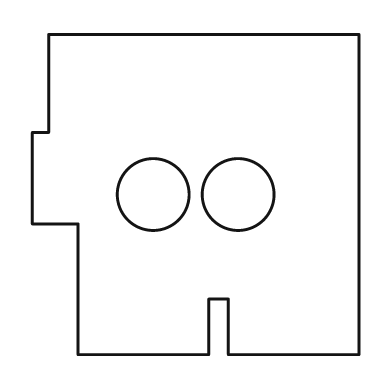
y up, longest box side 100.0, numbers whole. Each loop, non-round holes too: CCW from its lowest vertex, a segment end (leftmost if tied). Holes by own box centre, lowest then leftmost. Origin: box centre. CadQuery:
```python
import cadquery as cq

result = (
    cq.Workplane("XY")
    .moveTo(-36.0, -49.0)
    .lineTo(4.0, -49.0)
    .lineTo(4.0, -32.0)
    .lineTo(10.0, -32.0)
    .lineTo(10.0, -49.0)
    .lineTo(50.0, -49.0)
    .lineTo(50.0, 49.0)
    .lineTo(-45.0, 49.0)
    .lineTo(-45.0, 19.0)
    .lineTo(-50.0, 19.0)
    .lineTo(-50.0, -9.0)
    .lineTo(-36.0, -9.0)
    .close()
    .moveTo(-13.0, 0.0)
    .circle(11.0)
    .moveTo(13.0, 0.0)
    .circle(11.0)
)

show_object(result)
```